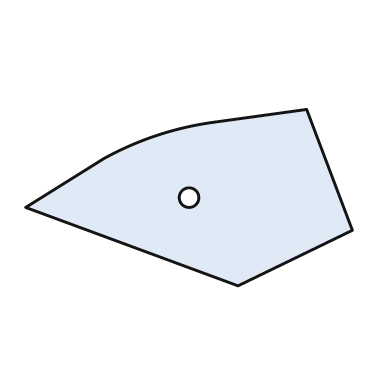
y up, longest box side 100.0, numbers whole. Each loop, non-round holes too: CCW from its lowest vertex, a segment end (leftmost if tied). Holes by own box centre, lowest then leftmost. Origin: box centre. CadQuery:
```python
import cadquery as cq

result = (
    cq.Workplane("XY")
    .moveTo(15.0, -27.0)
    .lineTo(50.0, -10.0)
    .lineTo(36.0, 27.0)
    .lineTo(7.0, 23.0)
    .threePointArc((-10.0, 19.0), (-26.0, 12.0))
    .lineTo(-50.0, -3.0)
    .close()
    .moveTo(0.0, 0.0)
    .circle(3.0)
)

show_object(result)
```